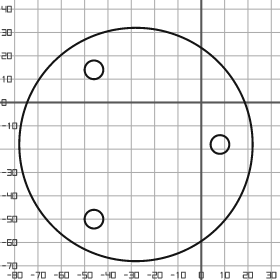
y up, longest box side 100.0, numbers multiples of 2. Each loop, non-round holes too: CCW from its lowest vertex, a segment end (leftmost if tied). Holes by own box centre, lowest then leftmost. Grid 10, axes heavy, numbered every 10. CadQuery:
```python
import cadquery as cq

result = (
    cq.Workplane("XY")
    .moveTo(-28.0, -18.0)
    .circle(50.0)
    .moveTo(-46.0, -50.0)
    .circle(4.0)
    .moveTo(8.0, -18.0)
    .circle(4.0)
    .moveTo(-46.0, 14.0)
    .circle(4.0)
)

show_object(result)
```